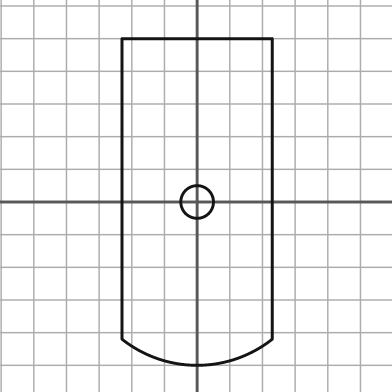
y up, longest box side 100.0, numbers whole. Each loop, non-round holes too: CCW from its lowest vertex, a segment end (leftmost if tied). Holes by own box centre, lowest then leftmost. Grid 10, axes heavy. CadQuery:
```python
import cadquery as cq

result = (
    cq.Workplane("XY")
    .moveTo(-23.0, -42.0)
    .threePointArc((0.0, -50.0), (23.0, -42.0))
    .lineTo(23.0, 50.0)
    .lineTo(-23.0, 50.0)
    .close()
    .moveTo(0.0, 0.0)
    .circle(5.0)
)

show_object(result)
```